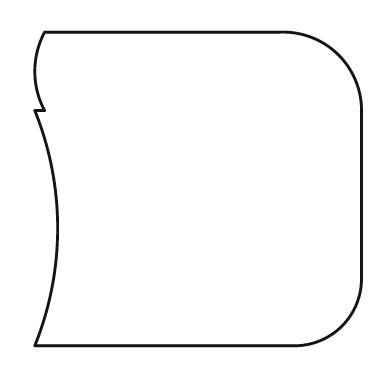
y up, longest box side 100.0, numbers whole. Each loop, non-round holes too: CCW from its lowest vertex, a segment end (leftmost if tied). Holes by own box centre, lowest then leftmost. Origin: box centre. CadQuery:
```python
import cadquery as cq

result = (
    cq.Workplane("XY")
    .moveTo(-50.0, -48.0)
    .lineTo(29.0, -48.0)
    .threePointArc((44.0, -42.0), (50.0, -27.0))
    .lineTo(50.0, 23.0)
    .threePointArc((43.0, 41.0), (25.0, 48.0))
    .lineTo(-47.0, 48.0)
    .threePointArc((-50.0, 36.0), (-47.0, 24.0))
    .lineTo(-50.0, 24.0)
    .threePointArc((-43.0, -12.0), (-50.0, -48.0))
    .close()
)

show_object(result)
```